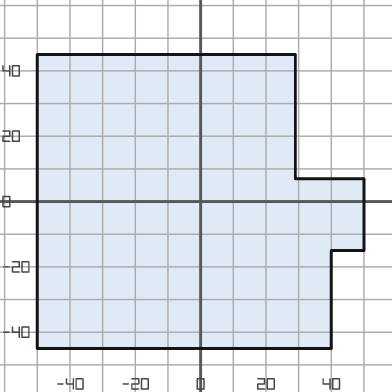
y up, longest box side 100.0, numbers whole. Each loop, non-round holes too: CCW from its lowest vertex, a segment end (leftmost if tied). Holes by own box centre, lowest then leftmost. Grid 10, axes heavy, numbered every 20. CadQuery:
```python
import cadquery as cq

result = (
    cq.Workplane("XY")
    .moveTo(-50.0, -45.0)
    .lineTo(40.0, -45.0)
    .lineTo(40.0, -15.0)
    .lineTo(50.0, -15.0)
    .lineTo(50.0, 7.0)
    .lineTo(29.0, 7.0)
    .lineTo(29.0, 45.0)
    .lineTo(-50.0, 45.0)
    .close()
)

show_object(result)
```